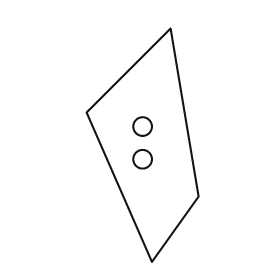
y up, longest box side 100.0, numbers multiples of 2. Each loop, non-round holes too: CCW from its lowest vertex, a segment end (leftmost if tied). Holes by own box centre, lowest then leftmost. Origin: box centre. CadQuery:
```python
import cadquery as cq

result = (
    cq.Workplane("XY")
    .moveTo(4.0, -50.0)
    .lineTo(24.0, -22.0)
    .lineTo(12.0, 50.0)
    .lineTo(-24.0, 14.0)
    .close()
    .moveTo(0.0, -6.0)
    .circle(4.0)
    .moveTo(0.0, 8.0)
    .circle(4.0)
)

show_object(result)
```